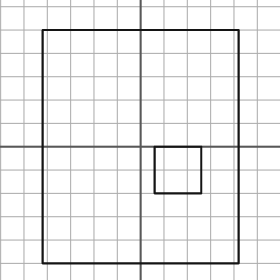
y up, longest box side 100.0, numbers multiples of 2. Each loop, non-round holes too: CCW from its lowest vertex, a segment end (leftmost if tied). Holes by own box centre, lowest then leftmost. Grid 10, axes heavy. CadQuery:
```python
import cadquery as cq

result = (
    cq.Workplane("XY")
    .moveTo(-42.0, -50.0)
    .lineTo(42.0, -50.0)
    .lineTo(42.0, 50.0)
    .lineTo(-42.0, 50.0)
    .close()
    .moveTo(6.0, -20.0)
    .lineTo(26.0, -20.0)
    .lineTo(26.0, 0.0)
    .lineTo(6.0, 0.0)
    .close()
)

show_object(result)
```